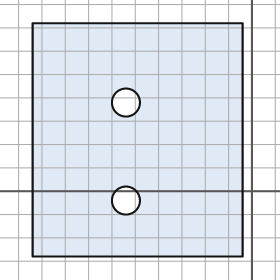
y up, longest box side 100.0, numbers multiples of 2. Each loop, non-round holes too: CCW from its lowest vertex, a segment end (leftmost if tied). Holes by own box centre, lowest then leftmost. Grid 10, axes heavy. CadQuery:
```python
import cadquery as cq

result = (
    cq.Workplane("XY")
    .moveTo(-94.0, -28.0)
    .lineTo(-4.0, -28.0)
    .lineTo(-4.0, 72.0)
    .lineTo(-94.0, 72.0)
    .close()
    .moveTo(-54.0, -4.0)
    .circle(6.0)
    .moveTo(-54.0, 38.0)
    .circle(6.0)
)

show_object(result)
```